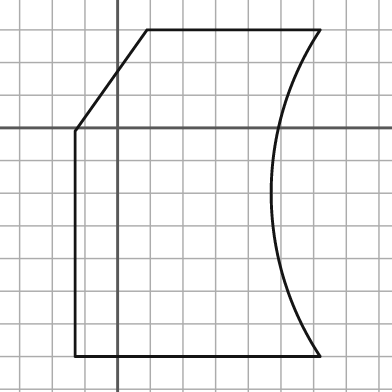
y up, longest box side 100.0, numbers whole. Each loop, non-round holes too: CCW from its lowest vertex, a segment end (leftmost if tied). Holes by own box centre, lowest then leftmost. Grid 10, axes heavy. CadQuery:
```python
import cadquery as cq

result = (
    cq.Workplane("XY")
    .moveTo(-13.0, -70.0)
    .lineTo(62.0, -70.0)
    .threePointArc((47.0, -20.0), (62.0, 30.0))
    .lineTo(9.0, 30.0)
    .lineTo(-13.0, -1.0)
    .close()
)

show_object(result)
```